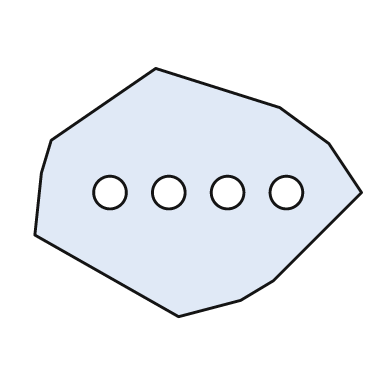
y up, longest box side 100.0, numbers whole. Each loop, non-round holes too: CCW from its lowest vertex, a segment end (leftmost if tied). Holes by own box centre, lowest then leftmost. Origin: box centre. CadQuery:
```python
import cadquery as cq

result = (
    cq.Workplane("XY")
    .moveTo(-6.0, -38.0)
    .lineTo(13.0, -33.0)
    .lineTo(23.0, -27.0)
    .lineTo(50.0, 0.0)
    .lineTo(40.0, 15.0)
    .lineTo(25.0, 26.0)
    .lineTo(-13.0, 38.0)
    .lineTo(-45.0, 16.0)
    .lineTo(-48.0, 6.0)
    .lineTo(-50.0, -13.0)
    .close()
    .moveTo(-27.0, 0.0)
    .circle(5.0)
    .moveTo(-9.0, 0.0)
    .circle(5.0)
    .moveTo(9.0, 0.0)
    .circle(5.0)
    .moveTo(27.0, 0.0)
    .circle(5.0)
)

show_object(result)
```